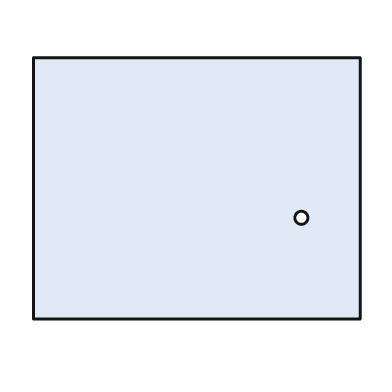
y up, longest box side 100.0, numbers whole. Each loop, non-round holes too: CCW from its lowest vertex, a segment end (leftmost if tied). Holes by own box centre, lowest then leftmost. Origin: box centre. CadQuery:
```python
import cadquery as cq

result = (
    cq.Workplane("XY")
    .moveTo(-50.0, -40.0)
    .lineTo(50.0, -40.0)
    .lineTo(50.0, 40.0)
    .lineTo(-50.0, 40.0)
    .close()
    .moveTo(32.0, -9.0)
    .circle(2.0)
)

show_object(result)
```